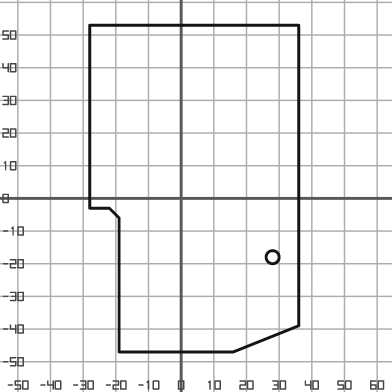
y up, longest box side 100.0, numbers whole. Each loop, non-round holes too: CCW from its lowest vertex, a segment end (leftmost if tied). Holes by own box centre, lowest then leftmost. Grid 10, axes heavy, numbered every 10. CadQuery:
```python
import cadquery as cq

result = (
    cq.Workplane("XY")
    .moveTo(-19.0, -47.0)
    .lineTo(16.0, -47.0)
    .lineTo(36.0, -39.0)
    .lineTo(36.0, 53.0)
    .lineTo(-28.0, 53.0)
    .lineTo(-28.0, -3.0)
    .lineTo(-22.0, -3.0)
    .lineTo(-19.0, -6.0)
    .close()
    .moveTo(28.0, -18.0)
    .circle(2.0)
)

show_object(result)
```